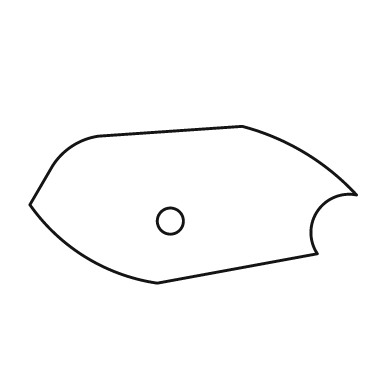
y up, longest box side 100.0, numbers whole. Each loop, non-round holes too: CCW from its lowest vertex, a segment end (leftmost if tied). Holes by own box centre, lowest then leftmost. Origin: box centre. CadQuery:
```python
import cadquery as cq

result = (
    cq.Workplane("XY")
    .moveTo(-11.0, -24.0)
    .lineTo(38.0, -15.0)
    .threePointArc((38.0, -2.0), (50.0, 3.0))
    .threePointArc((34.0, 16.0), (15.0, 24.0))
    .lineTo(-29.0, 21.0)
    .threePointArc((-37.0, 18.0), (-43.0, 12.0))
    .lineTo(-50.0, 0.0)
    .threePointArc((-33.0, -16.0), (-11.0, -24.0))
    .close()
    .moveTo(-7.0, -5.0)
    .circle(4.0)
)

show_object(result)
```